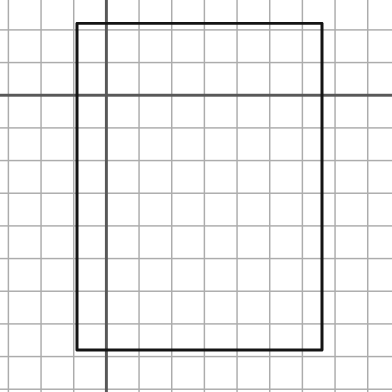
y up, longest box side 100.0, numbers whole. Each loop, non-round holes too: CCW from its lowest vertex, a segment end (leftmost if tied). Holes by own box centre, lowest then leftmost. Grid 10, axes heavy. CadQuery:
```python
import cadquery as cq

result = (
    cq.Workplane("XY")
    .moveTo(-9.0, -78.0)
    .lineTo(66.0, -78.0)
    .lineTo(66.0, 22.0)
    .lineTo(-9.0, 22.0)
    .close()
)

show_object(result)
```